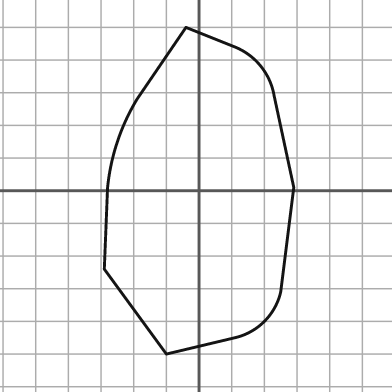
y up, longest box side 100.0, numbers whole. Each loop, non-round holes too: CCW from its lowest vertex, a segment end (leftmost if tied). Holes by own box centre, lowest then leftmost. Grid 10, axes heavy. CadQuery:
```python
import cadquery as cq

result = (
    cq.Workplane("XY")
    .moveTo(-10.0, -50.0)
    .lineTo(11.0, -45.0)
    .threePointArc((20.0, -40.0), (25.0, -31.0))
    .lineTo(29.0, 1.0)
    .lineTo(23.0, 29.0)
    .threePointArc((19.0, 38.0), (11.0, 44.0))
    .lineTo(-4.0, 50.0)
    .lineTo(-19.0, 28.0)
    .threePointArc((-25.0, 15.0), (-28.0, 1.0))
    .lineTo(-29.0, -24.0)
    .close()
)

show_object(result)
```